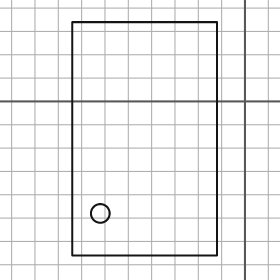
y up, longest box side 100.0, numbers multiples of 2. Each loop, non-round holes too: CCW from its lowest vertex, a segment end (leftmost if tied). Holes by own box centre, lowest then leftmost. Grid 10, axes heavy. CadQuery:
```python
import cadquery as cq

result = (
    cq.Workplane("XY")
    .moveTo(-74.0, -66.0)
    .lineTo(-12.0, -66.0)
    .lineTo(-12.0, 34.0)
    .lineTo(-74.0, 34.0)
    .close()
    .moveTo(-62.0, -48.0)
    .circle(4.0)
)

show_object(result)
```